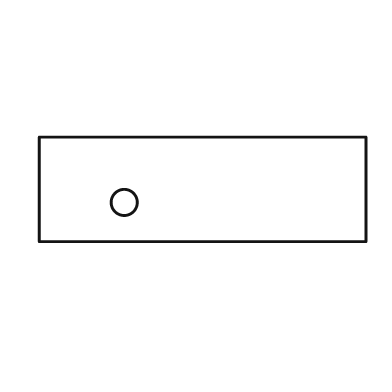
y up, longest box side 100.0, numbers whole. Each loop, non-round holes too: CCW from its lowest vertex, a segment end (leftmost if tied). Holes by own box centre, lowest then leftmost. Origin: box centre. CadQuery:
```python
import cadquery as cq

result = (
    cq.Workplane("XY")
    .moveTo(-50.0, -16.0)
    .lineTo(50.0, -16.0)
    .lineTo(50.0, 16.0)
    .lineTo(-50.0, 16.0)
    .close()
    .moveTo(-24.0, -4.0)
    .circle(4.0)
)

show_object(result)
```